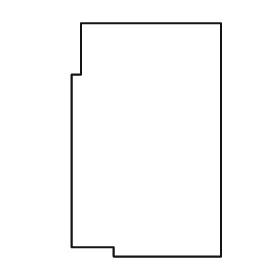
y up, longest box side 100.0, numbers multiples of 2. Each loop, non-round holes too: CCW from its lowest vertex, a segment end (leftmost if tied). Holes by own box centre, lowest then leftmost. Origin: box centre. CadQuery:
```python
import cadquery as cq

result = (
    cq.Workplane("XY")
    .moveTo(-14.0, -50.0)
    .lineTo(32.0, -50.0)
    .lineTo(32.0, 50.0)
    .lineTo(-28.0, 50.0)
    .lineTo(-28.0, 28.0)
    .lineTo(-32.0, 28.0)
    .lineTo(-32.0, -46.0)
    .lineTo(-14.0, -46.0)
    .close()
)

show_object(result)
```